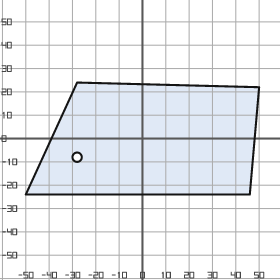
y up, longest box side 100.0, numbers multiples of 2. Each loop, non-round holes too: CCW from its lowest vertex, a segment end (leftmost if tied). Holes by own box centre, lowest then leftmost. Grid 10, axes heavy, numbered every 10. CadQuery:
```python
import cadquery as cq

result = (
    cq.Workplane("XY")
    .moveTo(-50.0, -24.0)
    .lineTo(46.0, -24.0)
    .lineTo(50.0, 22.0)
    .lineTo(-28.0, 24.0)
    .close()
    .moveTo(-28.0, -8.0)
    .circle(2.0)
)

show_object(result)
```